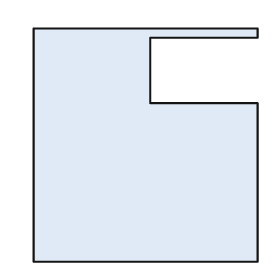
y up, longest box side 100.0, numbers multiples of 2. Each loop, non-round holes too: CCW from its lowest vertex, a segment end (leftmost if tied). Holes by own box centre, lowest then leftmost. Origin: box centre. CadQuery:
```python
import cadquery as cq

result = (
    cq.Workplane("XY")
    .moveTo(-48.0, -50.0)
    .lineTo(48.0, -50.0)
    .lineTo(48.0, 18.0)
    .lineTo(2.0, 18.0)
    .lineTo(2.0, 46.0)
    .lineTo(48.0, 46.0)
    .lineTo(48.0, 50.0)
    .lineTo(-48.0, 50.0)
    .close()
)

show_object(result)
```